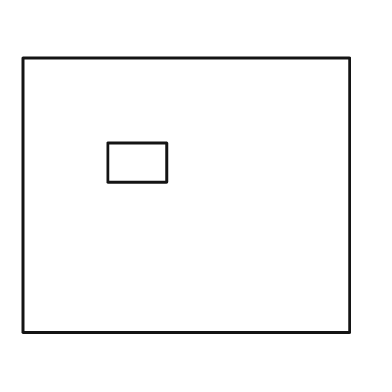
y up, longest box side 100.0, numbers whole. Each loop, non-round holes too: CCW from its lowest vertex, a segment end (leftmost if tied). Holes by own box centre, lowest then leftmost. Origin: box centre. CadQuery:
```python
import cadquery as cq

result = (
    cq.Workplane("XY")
    .moveTo(-50.0, -42.0)
    .lineTo(50.0, -42.0)
    .lineTo(50.0, 42.0)
    .lineTo(-50.0, 42.0)
    .close()
    .moveTo(-24.0, 4.0)
    .lineTo(-6.0, 4.0)
    .lineTo(-6.0, 16.0)
    .lineTo(-24.0, 16.0)
    .close()
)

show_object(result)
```